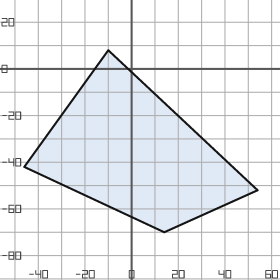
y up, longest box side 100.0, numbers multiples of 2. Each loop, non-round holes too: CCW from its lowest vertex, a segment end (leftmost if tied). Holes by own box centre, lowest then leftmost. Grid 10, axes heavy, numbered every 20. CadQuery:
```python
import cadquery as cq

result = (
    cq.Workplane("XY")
    .moveTo(14.0, -70.0)
    .lineTo(54.0, -52.0)
    .lineTo(-10.0, 8.0)
    .lineTo(-46.0, -42.0)
    .close()
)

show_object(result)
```